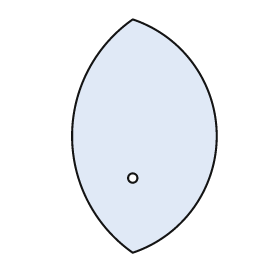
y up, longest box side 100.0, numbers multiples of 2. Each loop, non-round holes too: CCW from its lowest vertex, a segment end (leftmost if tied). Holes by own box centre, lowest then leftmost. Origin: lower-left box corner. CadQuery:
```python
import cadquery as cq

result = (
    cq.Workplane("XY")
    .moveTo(26.0, 0.0)
    .threePointArc((62.0, 50.0), (26.0, 100.0))
    .threePointArc((0.0, 50.0), (26.0, 0.0))
    .close()
    .moveTo(26.0, 32.0)
    .circle(2.0)
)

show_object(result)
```